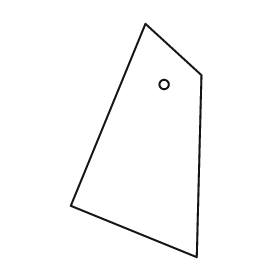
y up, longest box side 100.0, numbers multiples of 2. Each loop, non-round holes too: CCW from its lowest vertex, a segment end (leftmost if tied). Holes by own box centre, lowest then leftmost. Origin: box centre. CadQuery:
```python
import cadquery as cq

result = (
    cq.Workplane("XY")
    .moveTo(26.0, -50.0)
    .lineTo(28.0, 28.0)
    .lineTo(4.0, 50.0)
    .lineTo(-28.0, -28.0)
    .close()
    .moveTo(12.0, 24.0)
    .circle(2.0)
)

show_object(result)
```